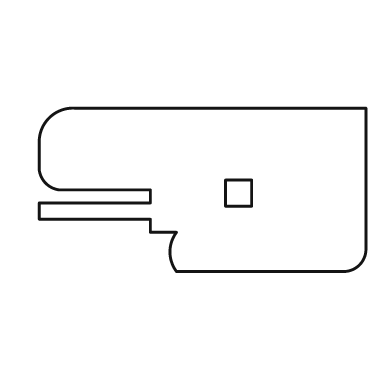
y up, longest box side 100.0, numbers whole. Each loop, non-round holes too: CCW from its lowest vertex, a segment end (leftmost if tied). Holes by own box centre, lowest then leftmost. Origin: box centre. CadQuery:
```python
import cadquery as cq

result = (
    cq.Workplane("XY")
    .moveTo(-8.0, -25.0)
    .lineTo(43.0, -25.0)
    .threePointArc((48.0, -23.0), (50.0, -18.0))
    .lineTo(50.0, 25.0)
    .lineTo(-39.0, 25.0)
    .threePointArc((-47.0, 22.0), (-50.0, 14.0))
    .lineTo(-50.0, 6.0)
    .threePointArc((-48.0, 2.0), (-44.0, 0.0))
    .lineTo(-16.0, 0.0)
    .lineTo(-16.0, -4.0)
    .lineTo(-50.0, -4.0)
    .lineTo(-50.0, -9.0)
    .lineTo(-16.0, -9.0)
    .lineTo(-16.0, -13.0)
    .lineTo(-8.0, -13.0)
    .threePointArc((-10.0, -19.0), (-8.0, -25.0))
    .close()
    .moveTo(7.0, -5.0)
    .lineTo(15.0, -5.0)
    .lineTo(15.0, 3.0)
    .lineTo(7.0, 3.0)
    .close()
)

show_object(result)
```